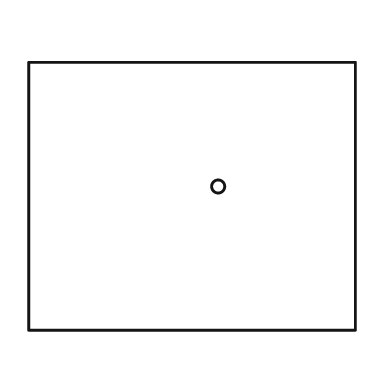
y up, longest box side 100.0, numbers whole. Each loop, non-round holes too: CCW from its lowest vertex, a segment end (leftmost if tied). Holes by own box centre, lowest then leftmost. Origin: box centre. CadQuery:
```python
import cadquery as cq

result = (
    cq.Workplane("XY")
    .moveTo(-50.0, -41.0)
    .lineTo(50.0, -41.0)
    .lineTo(50.0, 41.0)
    .lineTo(-50.0, 41.0)
    .close()
    .moveTo(8.0, 3.0)
    .circle(2.0)
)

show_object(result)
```